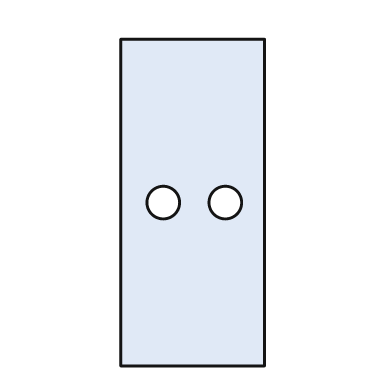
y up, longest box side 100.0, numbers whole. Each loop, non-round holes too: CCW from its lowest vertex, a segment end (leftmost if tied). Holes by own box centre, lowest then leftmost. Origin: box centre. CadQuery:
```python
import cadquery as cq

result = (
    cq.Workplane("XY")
    .moveTo(-22.0, -50.0)
    .lineTo(22.0, -50.0)
    .lineTo(22.0, 50.0)
    .lineTo(-22.0, 50.0)
    .close()
    .moveTo(-9.0, 0.0)
    .circle(5.0)
    .moveTo(10.0, 0.0)
    .circle(5.0)
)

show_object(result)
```